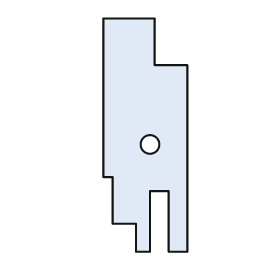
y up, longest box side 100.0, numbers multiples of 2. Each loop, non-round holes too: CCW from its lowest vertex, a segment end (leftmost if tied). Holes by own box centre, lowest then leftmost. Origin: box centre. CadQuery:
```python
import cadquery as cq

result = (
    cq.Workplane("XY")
    .moveTo(-4.0, -50.0)
    .lineTo(2.0, -50.0)
    .lineTo(2.0, -24.0)
    .lineTo(10.0, -24.0)
    .lineTo(10.0, -50.0)
    .lineTo(18.0, -50.0)
    .lineTo(18.0, 30.0)
    .lineTo(4.0, 30.0)
    .lineTo(4.0, 50.0)
    .lineTo(-18.0, 50.0)
    .lineTo(-18.0, -18.0)
    .lineTo(-14.0, -18.0)
    .lineTo(-14.0, -38.0)
    .lineTo(-4.0, -38.0)
    .close()
    .moveTo(2.0, -4.0)
    .circle(4.0)
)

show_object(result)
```